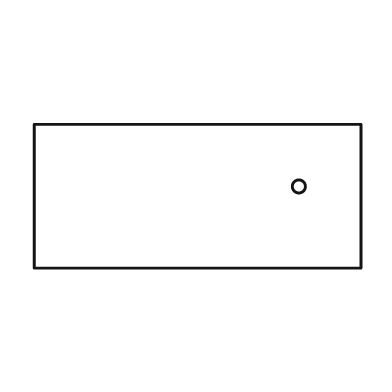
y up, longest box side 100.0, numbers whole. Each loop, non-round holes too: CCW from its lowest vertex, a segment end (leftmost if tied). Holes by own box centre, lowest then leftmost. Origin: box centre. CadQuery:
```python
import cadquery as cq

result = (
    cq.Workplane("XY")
    .moveTo(-50.0, -22.0)
    .lineTo(50.0, -22.0)
    .lineTo(50.0, 22.0)
    .lineTo(-50.0, 22.0)
    .close()
    .moveTo(31.0, 3.0)
    .circle(2.0)
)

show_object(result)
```